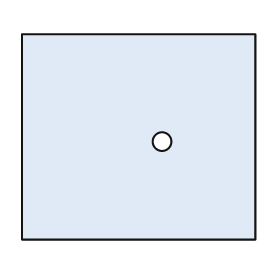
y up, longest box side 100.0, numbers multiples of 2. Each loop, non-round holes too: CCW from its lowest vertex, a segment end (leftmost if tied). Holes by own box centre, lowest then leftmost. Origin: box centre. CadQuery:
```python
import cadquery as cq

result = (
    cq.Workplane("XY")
    .moveTo(-50.0, -44.0)
    .lineTo(50.0, -44.0)
    .lineTo(50.0, 44.0)
    .lineTo(-50.0, 44.0)
    .close()
    .moveTo(10.0, -2.0)
    .circle(4.0)
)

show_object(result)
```